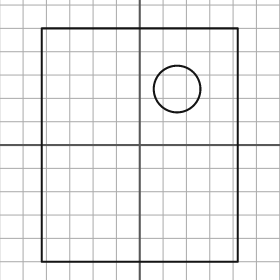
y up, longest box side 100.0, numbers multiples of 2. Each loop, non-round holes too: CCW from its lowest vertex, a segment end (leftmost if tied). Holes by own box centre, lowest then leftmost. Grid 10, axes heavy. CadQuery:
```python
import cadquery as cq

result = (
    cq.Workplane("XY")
    .moveTo(-42.0, -50.0)
    .lineTo(42.0, -50.0)
    .lineTo(42.0, 50.0)
    .lineTo(-42.0, 50.0)
    .close()
    .moveTo(16.0, 24.0)
    .circle(10.0)
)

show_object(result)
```